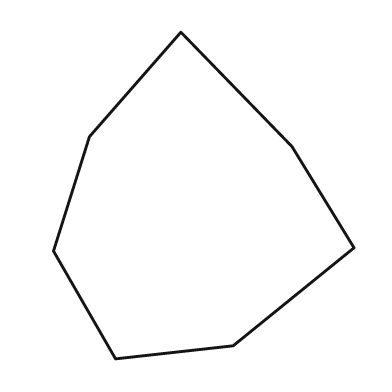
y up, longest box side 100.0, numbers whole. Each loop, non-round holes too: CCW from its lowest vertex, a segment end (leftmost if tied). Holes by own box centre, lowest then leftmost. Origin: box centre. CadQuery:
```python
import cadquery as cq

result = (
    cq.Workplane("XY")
    .moveTo(-27.0, -50.0)
    .lineTo(9.0, -46.0)
    .lineTo(46.0, -16.0)
    .lineTo(27.0, 15.0)
    .lineTo(-7.0, 50.0)
    .lineTo(-35.0, 18.0)
    .lineTo(-46.0, -17.0)
    .close()
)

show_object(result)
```